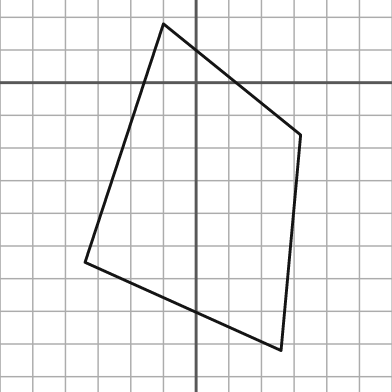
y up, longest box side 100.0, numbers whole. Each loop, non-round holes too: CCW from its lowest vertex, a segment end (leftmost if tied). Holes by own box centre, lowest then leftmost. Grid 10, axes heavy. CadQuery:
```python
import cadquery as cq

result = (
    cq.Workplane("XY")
    .moveTo(26.0, -82.0)
    .lineTo(32.0, -16.0)
    .lineTo(-10.0, 18.0)
    .lineTo(-34.0, -55.0)
    .close()
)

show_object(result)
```